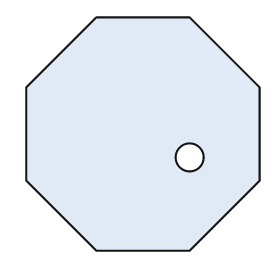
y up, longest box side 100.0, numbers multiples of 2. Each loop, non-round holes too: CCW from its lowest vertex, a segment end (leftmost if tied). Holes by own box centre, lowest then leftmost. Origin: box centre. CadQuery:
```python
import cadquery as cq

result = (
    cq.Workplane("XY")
    .moveTo(-20.0, -50.0)
    .lineTo(20.0, -50.0)
    .lineTo(50.0, -20.0)
    .lineTo(50.0, 20.0)
    .lineTo(20.0, 50.0)
    .lineTo(-20.0, 50.0)
    .lineTo(-50.0, 20.0)
    .lineTo(-50.0, -20.0)
    .close()
    .moveTo(20.0, -10.0)
    .circle(6.0)
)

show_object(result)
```